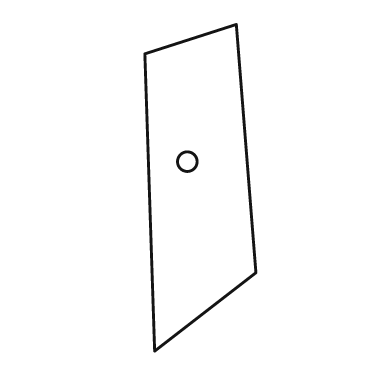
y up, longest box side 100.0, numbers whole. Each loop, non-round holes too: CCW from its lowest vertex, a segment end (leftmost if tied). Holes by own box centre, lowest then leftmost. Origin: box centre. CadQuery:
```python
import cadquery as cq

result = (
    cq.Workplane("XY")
    .moveTo(-14.0, -50.0)
    .lineTo(17.0, -26.0)
    .lineTo(11.0, 50.0)
    .lineTo(-17.0, 41.0)
    .close()
    .moveTo(-4.0, 8.0)
    .circle(3.0)
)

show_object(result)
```